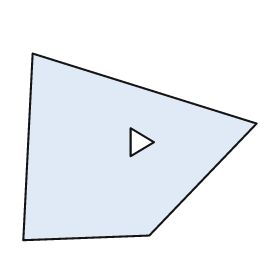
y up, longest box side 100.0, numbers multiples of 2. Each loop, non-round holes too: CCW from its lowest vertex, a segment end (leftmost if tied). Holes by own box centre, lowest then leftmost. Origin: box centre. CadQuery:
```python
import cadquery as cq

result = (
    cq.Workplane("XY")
    .moveTo(-50.0, -40.0)
    .lineTo(4.0, -38.0)
    .lineTo(50.0, 10.0)
    .lineTo(-46.0, 40.0)
    .close()
    .moveTo(-4.0, -4.0)
    .lineTo(6.0, 2.0)
    .lineTo(-4.0, 8.0)
    .close()
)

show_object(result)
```